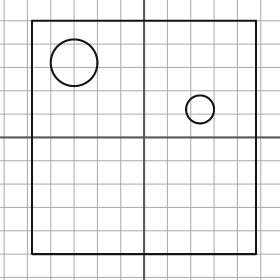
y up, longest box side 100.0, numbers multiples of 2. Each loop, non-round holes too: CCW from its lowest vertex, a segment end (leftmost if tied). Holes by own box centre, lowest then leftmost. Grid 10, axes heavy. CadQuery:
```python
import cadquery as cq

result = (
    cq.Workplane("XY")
    .moveTo(-48.0, -50.0)
    .lineTo(48.0, -50.0)
    .lineTo(48.0, 50.0)
    .lineTo(-48.0, 50.0)
    .close()
    .moveTo(24.0, 12.0)
    .circle(6.0)
    .moveTo(-30.0, 32.0)
    .circle(10.0)
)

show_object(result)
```